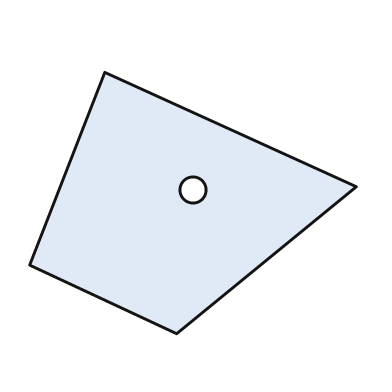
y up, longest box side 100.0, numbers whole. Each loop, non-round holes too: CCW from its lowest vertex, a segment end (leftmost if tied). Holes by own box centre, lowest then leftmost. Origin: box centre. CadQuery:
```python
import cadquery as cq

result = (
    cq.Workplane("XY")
    .moveTo(-5.0, -40.0)
    .lineTo(50.0, 5.0)
    .lineTo(-27.0, 40.0)
    .lineTo(-50.0, -19.0)
    .close()
    .moveTo(0.0, 4.0)
    .circle(4.0)
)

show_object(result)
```